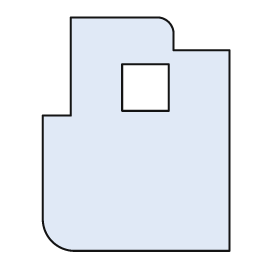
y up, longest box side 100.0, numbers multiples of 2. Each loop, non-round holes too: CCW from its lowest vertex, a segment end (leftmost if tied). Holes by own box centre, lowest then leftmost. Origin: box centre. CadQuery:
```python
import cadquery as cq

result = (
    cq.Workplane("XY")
    .moveTo(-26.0, -50.0)
    .lineTo(40.0, -50.0)
    .lineTo(40.0, 36.0)
    .lineTo(16.0, 36.0)
    .lineTo(16.0, 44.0)
    .threePointArc((14.0, 48.0), (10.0, 50.0))
    .lineTo(-28.0, 50.0)
    .lineTo(-28.0, 8.0)
    .lineTo(-40.0, 8.0)
    .lineTo(-40.0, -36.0)
    .threePointArc((-36.0, -46.0), (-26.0, -50.0))
    .close()
    .moveTo(-6.0, 10.0)
    .lineTo(14.0, 10.0)
    .lineTo(14.0, 30.0)
    .lineTo(-6.0, 30.0)
    .close()
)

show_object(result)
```